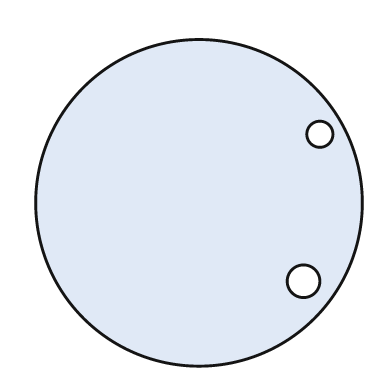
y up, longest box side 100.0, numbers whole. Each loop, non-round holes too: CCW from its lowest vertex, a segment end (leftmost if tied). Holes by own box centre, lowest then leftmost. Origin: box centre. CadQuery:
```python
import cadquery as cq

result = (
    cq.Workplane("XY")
    .moveTo(0.0, 0.0)
    .circle(50.0)
    .moveTo(32.0, -24.0)
    .circle(5.0)
    .moveTo(37.0, 21.0)
    .circle(4.0)
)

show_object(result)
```